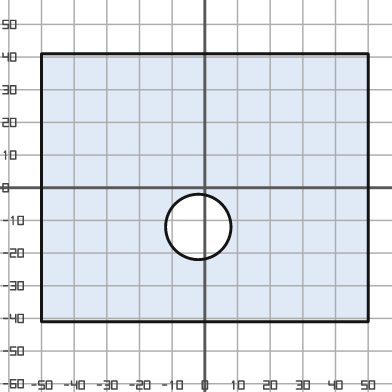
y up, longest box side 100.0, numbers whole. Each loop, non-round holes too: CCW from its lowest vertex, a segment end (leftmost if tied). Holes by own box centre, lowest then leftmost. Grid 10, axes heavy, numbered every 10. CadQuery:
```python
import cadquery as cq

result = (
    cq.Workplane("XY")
    .moveTo(-50.0, -41.0)
    .lineTo(50.0, -41.0)
    .lineTo(50.0, 41.0)
    .lineTo(-50.0, 41.0)
    .close()
    .moveTo(-2.0, -12.0)
    .circle(10.0)
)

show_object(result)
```